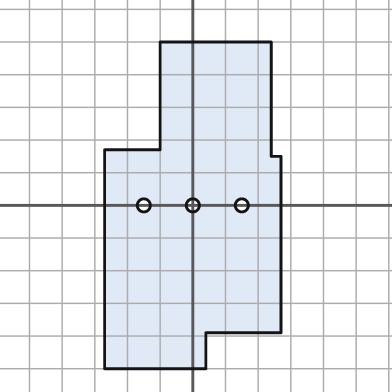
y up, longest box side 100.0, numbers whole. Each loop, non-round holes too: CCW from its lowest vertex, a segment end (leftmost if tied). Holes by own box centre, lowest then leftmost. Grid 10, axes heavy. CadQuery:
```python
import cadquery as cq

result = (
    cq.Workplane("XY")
    .moveTo(-27.0, -50.0)
    .lineTo(4.0, -50.0)
    .lineTo(4.0, -39.0)
    .lineTo(27.0, -39.0)
    .lineTo(27.0, 15.0)
    .lineTo(24.0, 15.0)
    .lineTo(24.0, 50.0)
    .lineTo(-10.0, 50.0)
    .lineTo(-10.0, 17.0)
    .lineTo(-27.0, 17.0)
    .close()
    .moveTo(-15.0, 0.0)
    .circle(2.0)
    .moveTo(0.0, 0.0)
    .circle(2.0)
    .moveTo(15.0, 0.0)
    .circle(2.0)
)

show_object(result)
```